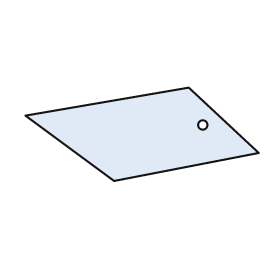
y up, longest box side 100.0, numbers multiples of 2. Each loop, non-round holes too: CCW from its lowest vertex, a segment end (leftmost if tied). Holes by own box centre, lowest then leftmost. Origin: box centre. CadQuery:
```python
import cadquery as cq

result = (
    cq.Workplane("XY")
    .moveTo(-12.0, -20.0)
    .lineTo(50.0, -8.0)
    .lineTo(20.0, 20.0)
    .lineTo(-50.0, 8.0)
    .close()
    .moveTo(26.0, 4.0)
    .circle(2.0)
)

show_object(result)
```